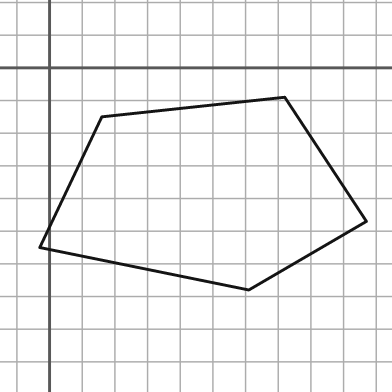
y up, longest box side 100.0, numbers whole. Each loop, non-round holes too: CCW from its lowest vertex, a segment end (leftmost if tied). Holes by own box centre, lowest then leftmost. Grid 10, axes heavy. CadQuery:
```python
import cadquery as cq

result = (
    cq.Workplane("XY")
    .moveTo(61.0, -68.0)
    .lineTo(97.0, -47.0)
    .lineTo(72.0, -9.0)
    .lineTo(16.0, -15.0)
    .lineTo(-3.0, -55.0)
    .close()
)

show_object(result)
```